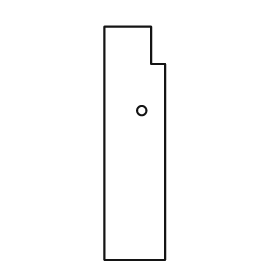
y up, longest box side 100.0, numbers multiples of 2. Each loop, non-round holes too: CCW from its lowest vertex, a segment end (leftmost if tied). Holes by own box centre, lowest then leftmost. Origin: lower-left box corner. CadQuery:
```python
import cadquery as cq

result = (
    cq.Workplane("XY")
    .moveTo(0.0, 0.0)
    .lineTo(26.0, 0.0)
    .lineTo(26.0, 84.0)
    .lineTo(20.0, 84.0)
    .lineTo(20.0, 100.0)
    .lineTo(0.0, 100.0)
    .close()
    .moveTo(16.0, 64.0)
    .circle(2.0)
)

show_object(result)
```